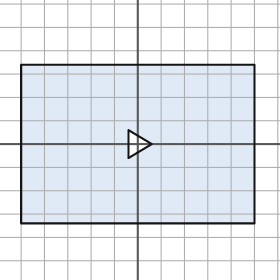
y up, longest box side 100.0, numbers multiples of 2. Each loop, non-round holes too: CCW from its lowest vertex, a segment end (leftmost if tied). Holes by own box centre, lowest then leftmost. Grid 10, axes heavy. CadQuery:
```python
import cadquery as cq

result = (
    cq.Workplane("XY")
    .moveTo(-50.0, -34.0)
    .lineTo(50.0, -34.0)
    .lineTo(50.0, 34.0)
    .lineTo(-50.0, 34.0)
    .close()
    .moveTo(-4.0, -6.0)
    .lineTo(6.0, 0.0)
    .lineTo(-4.0, 6.0)
    .close()
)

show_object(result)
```